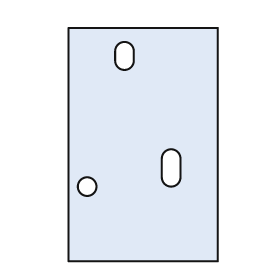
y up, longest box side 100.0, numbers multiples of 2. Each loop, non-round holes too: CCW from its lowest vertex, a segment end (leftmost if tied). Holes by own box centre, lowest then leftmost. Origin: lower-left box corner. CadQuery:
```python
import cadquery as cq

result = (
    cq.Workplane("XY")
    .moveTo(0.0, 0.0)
    .lineTo(64.0, 0.0)
    .lineTo(64.0, 100.0)
    .lineTo(0.0, 100.0)
    .close()
    .moveTo(8.0, 32.0)
    .circle(4.0)
    .moveTo(40.0, 36.0)
    .threePointArc((44.0, 32.0), (48.0, 36.0))
    .lineTo(48.0, 44.0)
    .threePointArc((44.0, 48.0), (40.0, 44.0))
    .close()
    .moveTo(20.0, 86.0)
    .threePointArc((24.0, 82.0), (28.0, 86.0))
    .lineTo(28.0, 90.0)
    .threePointArc((24.0, 94.0), (20.0, 90.0))
    .close()
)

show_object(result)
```